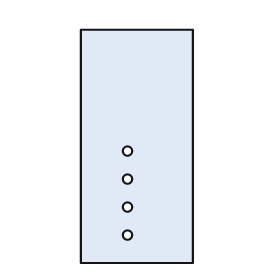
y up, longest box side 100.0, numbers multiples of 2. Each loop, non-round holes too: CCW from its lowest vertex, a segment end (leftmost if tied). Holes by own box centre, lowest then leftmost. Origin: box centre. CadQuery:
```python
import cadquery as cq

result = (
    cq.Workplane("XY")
    .moveTo(-24.0, -50.0)
    .lineTo(24.0, -50.0)
    .lineTo(24.0, 50.0)
    .lineTo(-24.0, 50.0)
    .close()
    .moveTo(-4.0, -38.0)
    .circle(2.0)
    .moveTo(-4.0, -26.0)
    .circle(2.0)
    .moveTo(-4.0, -14.0)
    .circle(2.0)
    .moveTo(-4.0, -2.0)
    .circle(2.0)
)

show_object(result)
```